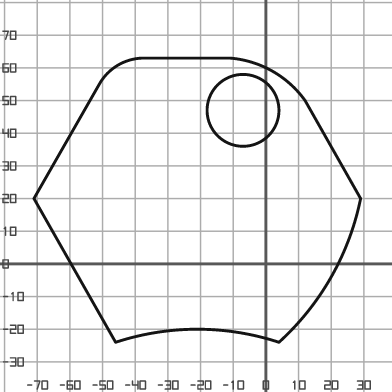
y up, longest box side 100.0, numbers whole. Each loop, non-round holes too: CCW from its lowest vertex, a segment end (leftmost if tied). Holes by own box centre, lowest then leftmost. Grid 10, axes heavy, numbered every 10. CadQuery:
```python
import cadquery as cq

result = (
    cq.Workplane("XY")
    .moveTo(-46.0, -24.0)
    .threePointArc((-21.0, -20.0), (4.0, -24.0))
    .threePointArc((20.0, -4.0), (29.0, 20.0))
    .lineTo(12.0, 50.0)
    .threePointArc((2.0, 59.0), (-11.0, 63.0))
    .lineTo(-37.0, 63.0)
    .threePointArc((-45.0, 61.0), (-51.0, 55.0))
    .lineTo(-71.0, 20.0)
    .close()
    .moveTo(-7.0, 47.0)
    .circle(11.0)
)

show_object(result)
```